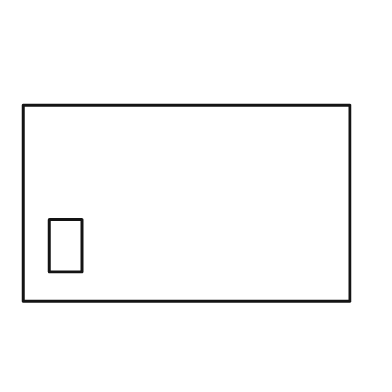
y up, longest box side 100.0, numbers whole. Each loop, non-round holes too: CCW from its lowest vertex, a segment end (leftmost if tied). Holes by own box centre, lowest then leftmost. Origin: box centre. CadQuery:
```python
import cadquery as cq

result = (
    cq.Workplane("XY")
    .moveTo(-50.0, -30.0)
    .lineTo(50.0, -30.0)
    .lineTo(50.0, 30.0)
    .lineTo(-50.0, 30.0)
    .close()
    .moveTo(-42.0, -21.0)
    .lineTo(-32.0, -21.0)
    .lineTo(-32.0, -5.0)
    .lineTo(-42.0, -5.0)
    .close()
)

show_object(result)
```